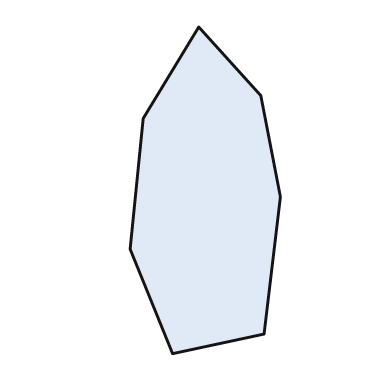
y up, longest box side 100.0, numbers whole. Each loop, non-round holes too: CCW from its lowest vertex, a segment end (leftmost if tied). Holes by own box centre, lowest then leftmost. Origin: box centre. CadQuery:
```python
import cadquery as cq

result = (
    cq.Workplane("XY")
    .moveTo(-10.0, -50.0)
    .lineTo(18.0, -44.0)
    .lineTo(23.0, -2.0)
    .lineTo(17.0, 29.0)
    .lineTo(-2.0, 50.0)
    .lineTo(-19.0, 22.0)
    .lineTo(-23.0, -18.0)
    .close()
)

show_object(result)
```